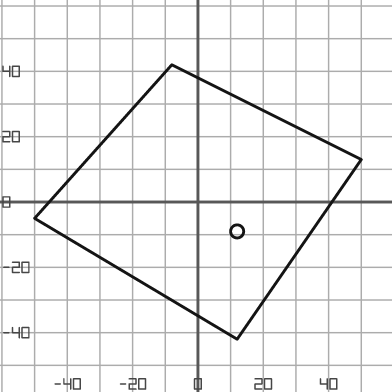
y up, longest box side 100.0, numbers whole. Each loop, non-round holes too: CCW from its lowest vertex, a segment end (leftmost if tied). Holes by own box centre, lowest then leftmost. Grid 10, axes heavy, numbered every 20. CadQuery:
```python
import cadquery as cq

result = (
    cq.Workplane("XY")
    .moveTo(12.0, -42.0)
    .lineTo(50.0, 13.0)
    .lineTo(-8.0, 42.0)
    .lineTo(-50.0, -5.0)
    .close()
    .moveTo(12.0, -9.0)
    .circle(2.0)
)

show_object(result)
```